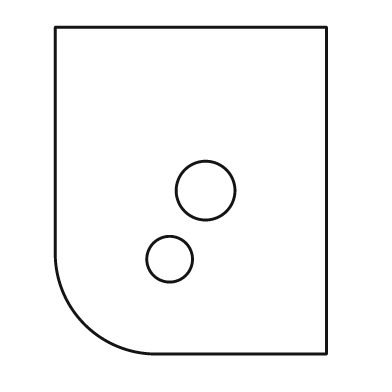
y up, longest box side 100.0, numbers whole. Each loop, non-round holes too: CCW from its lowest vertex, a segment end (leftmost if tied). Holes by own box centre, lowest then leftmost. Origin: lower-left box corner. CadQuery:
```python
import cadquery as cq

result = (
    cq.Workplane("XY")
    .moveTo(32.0, 0.0)
    .lineTo(83.0, 0.0)
    .lineTo(83.0, 100.0)
    .lineTo(0.0, 100.0)
    .lineTo(0.0, 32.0)
    .threePointArc((9.0, 9.0), (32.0, 0.0))
    .close()
    .moveTo(35.0, 29.0)
    .circle(7.0)
    .moveTo(46.0, 50.0)
    .circle(9.0)
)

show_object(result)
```